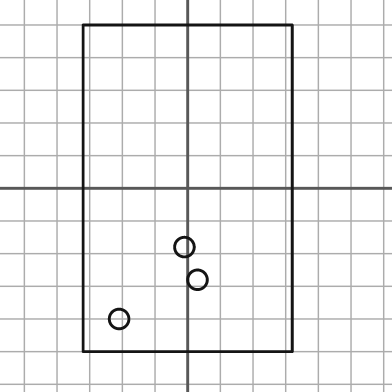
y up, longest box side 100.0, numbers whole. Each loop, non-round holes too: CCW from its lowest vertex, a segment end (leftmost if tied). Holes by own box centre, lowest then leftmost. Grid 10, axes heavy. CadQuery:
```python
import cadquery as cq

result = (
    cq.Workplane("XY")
    .moveTo(-32.0, -50.0)
    .lineTo(32.0, -50.0)
    .lineTo(32.0, 50.0)
    .lineTo(-32.0, 50.0)
    .close()
    .moveTo(-21.0, -40.0)
    .circle(3.0)
    .moveTo(3.0, -28.0)
    .circle(3.0)
    .moveTo(-1.0, -18.0)
    .circle(3.0)
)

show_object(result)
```